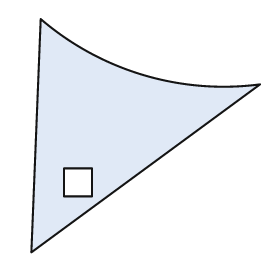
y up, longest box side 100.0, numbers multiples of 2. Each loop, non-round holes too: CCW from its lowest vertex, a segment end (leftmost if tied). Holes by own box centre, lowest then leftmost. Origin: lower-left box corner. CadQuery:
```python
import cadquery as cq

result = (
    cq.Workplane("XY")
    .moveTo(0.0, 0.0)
    .lineTo(98.0, 72.0)
    .threePointArc((48.0, 76.0), (4.0, 100.0))
    .close()
    .moveTo(14.0, 24.0)
    .lineTo(26.0, 24.0)
    .lineTo(26.0, 36.0)
    .lineTo(14.0, 36.0)
    .close()
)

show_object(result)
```